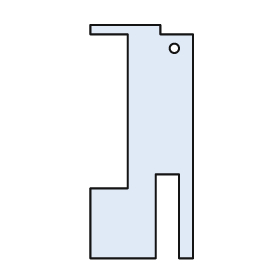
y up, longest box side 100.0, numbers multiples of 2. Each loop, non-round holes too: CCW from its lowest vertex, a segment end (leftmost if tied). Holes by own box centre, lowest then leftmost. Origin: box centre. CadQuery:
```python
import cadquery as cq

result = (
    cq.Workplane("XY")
    .moveTo(-22.0, -50.0)
    .lineTo(6.0, -50.0)
    .lineTo(6.0, -14.0)
    .lineTo(16.0, -14.0)
    .lineTo(16.0, -50.0)
    .lineTo(22.0, -50.0)
    .lineTo(22.0, 46.0)
    .lineTo(8.0, 46.0)
    .lineTo(8.0, 50.0)
    .lineTo(-22.0, 50.0)
    .lineTo(-22.0, 46.0)
    .lineTo(-6.0, 46.0)
    .lineTo(-6.0, -20.0)
    .lineTo(-22.0, -20.0)
    .close()
    .moveTo(14.0, 40.0)
    .circle(2.0)
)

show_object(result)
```